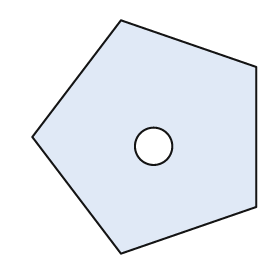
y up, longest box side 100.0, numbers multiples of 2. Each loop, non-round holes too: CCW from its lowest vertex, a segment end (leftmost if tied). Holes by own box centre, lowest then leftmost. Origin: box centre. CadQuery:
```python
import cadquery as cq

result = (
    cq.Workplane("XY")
    .moveTo(-10.0, -50.0)
    .lineTo(48.0, -30.0)
    .lineTo(48.0, 30.0)
    .lineTo(-10.0, 50.0)
    .lineTo(-48.0, 0.0)
    .close()
    .moveTo(4.0, -4.0)
    .circle(8.0)
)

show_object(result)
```